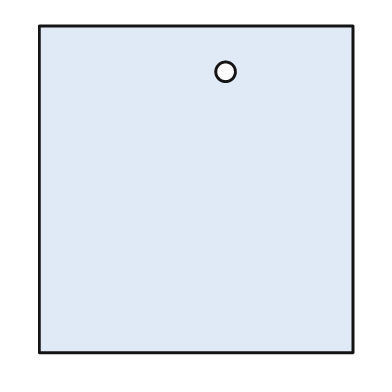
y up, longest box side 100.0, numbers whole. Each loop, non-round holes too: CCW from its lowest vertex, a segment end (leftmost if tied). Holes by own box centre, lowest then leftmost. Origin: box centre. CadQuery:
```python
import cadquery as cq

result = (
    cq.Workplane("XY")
    .moveTo(-48.0, -50.0)
    .lineTo(48.0, -50.0)
    .lineTo(48.0, 50.0)
    .lineTo(-48.0, 50.0)
    .close()
    .moveTo(9.0, 36.0)
    .circle(3.0)
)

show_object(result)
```